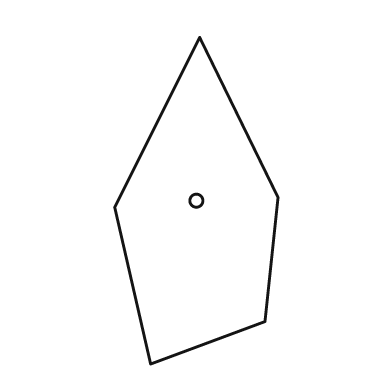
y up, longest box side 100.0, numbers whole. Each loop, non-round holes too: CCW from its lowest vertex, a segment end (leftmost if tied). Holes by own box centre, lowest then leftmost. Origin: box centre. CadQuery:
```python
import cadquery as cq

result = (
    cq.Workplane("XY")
    .moveTo(-14.0, -50.0)
    .lineTo(21.0, -37.0)
    .lineTo(25.0, 1.0)
    .lineTo(1.0, 50.0)
    .lineTo(-25.0, -2.0)
    .close()
    .moveTo(0.0, 0.0)
    .circle(2.0)
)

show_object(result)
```